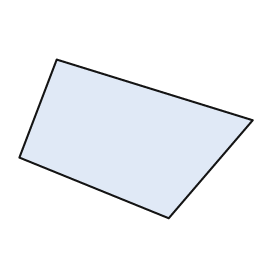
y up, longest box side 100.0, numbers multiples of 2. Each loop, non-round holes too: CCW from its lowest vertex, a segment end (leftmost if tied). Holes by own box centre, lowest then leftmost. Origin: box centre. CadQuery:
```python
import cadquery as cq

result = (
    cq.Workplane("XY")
    .moveTo(14.0, -34.0)
    .lineTo(50.0, 8.0)
    .lineTo(-34.0, 34.0)
    .lineTo(-50.0, -8.0)
    .close()
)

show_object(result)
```